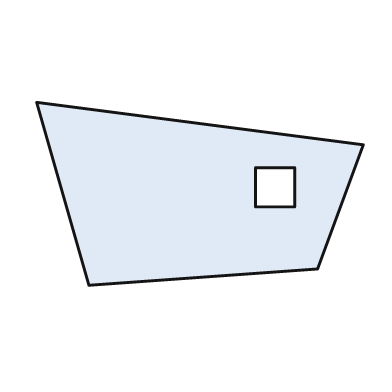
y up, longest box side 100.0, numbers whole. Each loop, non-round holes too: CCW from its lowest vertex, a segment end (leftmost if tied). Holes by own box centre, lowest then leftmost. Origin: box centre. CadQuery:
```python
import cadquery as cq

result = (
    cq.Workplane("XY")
    .moveTo(-34.0, -28.0)
    .lineTo(36.0, -23.0)
    .lineTo(50.0, 15.0)
    .lineTo(-50.0, 28.0)
    .close()
    .moveTo(17.0, -4.0)
    .lineTo(29.0, -4.0)
    .lineTo(29.0, 8.0)
    .lineTo(17.0, 8.0)
    .close()
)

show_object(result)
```